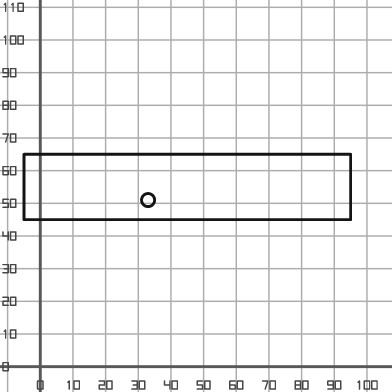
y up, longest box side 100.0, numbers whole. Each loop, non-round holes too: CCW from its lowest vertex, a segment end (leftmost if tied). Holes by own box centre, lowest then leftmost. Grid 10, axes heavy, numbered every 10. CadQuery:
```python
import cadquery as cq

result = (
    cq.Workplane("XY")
    .moveTo(-5.0, 45.0)
    .lineTo(95.0, 45.0)
    .lineTo(95.0, 65.0)
    .lineTo(-5.0, 65.0)
    .close()
    .moveTo(33.0, 51.0)
    .circle(2.0)
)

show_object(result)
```